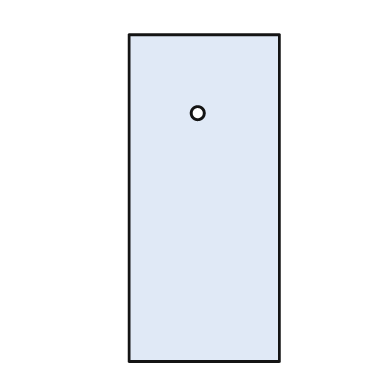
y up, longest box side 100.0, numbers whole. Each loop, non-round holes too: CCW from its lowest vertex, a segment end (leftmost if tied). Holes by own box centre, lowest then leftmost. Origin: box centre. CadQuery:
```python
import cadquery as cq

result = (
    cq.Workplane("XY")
    .moveTo(-23.0, -50.0)
    .lineTo(23.0, -50.0)
    .lineTo(23.0, 50.0)
    .lineTo(-23.0, 50.0)
    .close()
    .moveTo(-2.0, 26.0)
    .circle(2.0)
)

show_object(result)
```